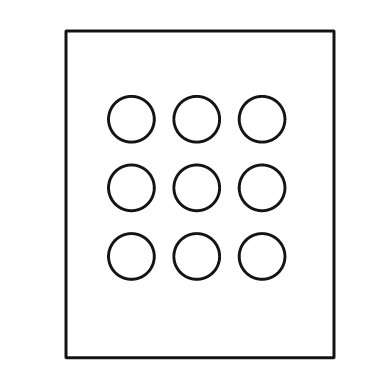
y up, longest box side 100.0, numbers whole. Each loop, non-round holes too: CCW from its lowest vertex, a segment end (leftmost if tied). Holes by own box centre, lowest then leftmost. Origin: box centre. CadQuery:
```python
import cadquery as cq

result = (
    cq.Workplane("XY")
    .moveTo(-41.0, -50.0)
    .lineTo(41.0, -50.0)
    .lineTo(41.0, 50.0)
    .lineTo(-41.0, 50.0)
    .close()
    .moveTo(-21.0, -19.0)
    .circle(7.0)
    .moveTo(-1.0, -19.0)
    .circle(7.0)
    .moveTo(19.0, -19.0)
    .circle(7.0)
    .moveTo(-21.0, 2.0)
    .circle(7.0)
    .moveTo(-1.0, 2.0)
    .circle(7.0)
    .moveTo(19.0, 2.0)
    .circle(7.0)
    .moveTo(-21.0, 23.0)
    .circle(7.0)
    .moveTo(-1.0, 23.0)
    .circle(7.0)
    .moveTo(19.0, 23.0)
    .circle(7.0)
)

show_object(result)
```